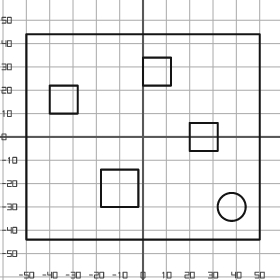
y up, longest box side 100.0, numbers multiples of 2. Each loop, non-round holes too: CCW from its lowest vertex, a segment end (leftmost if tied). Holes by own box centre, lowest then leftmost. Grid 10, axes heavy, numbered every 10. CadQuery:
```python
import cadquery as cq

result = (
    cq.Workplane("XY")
    .moveTo(-50.0, -44.0)
    .lineTo(50.0, -44.0)
    .lineTo(50.0, 44.0)
    .lineTo(-50.0, 44.0)
    .close()
    .moveTo(38.0, -30.0)
    .circle(6.0)
    .moveTo(-18.0, -30.0)
    .lineTo(-2.0, -30.0)
    .lineTo(-2.0, -14.0)
    .lineTo(-18.0, -14.0)
    .close()
    .moveTo(20.0, -6.0)
    .lineTo(32.0, -6.0)
    .lineTo(32.0, 6.0)
    .lineTo(20.0, 6.0)
    .close()
    .moveTo(-40.0, 10.0)
    .lineTo(-28.0, 10.0)
    .lineTo(-28.0, 22.0)
    .lineTo(-40.0, 22.0)
    .close()
    .moveTo(0.0, 22.0)
    .lineTo(12.0, 22.0)
    .lineTo(12.0, 34.0)
    .lineTo(0.0, 34.0)
    .close()
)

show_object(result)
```